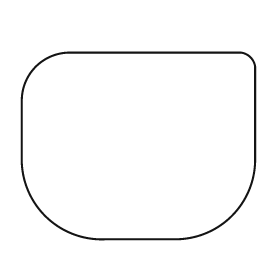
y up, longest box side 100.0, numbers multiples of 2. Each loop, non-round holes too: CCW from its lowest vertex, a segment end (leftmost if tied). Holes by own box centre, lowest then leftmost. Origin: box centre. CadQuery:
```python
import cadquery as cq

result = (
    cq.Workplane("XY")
    .moveTo(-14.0, -40.0)
    .lineTo(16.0, -40.0)
    .threePointArc((40.0, -30.0), (50.0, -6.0))
    .lineTo(50.0, 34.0)
    .threePointArc((48.0, 38.0), (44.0, 40.0))
    .lineTo(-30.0, 40.0)
    .threePointArc((-44.0, 34.0), (-50.0, 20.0))
    .lineTo(-50.0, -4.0)
    .threePointArc((-40.0, -30.0), (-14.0, -40.0))
    .close()
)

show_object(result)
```